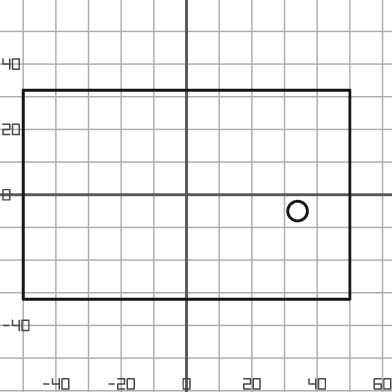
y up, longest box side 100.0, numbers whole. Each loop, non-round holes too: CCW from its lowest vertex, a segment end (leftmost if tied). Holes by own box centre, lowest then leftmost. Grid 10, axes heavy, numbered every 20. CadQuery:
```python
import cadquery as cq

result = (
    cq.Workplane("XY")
    .moveTo(-50.0, -32.0)
    .lineTo(50.0, -32.0)
    .lineTo(50.0, 32.0)
    .lineTo(-50.0, 32.0)
    .close()
    .moveTo(34.0, -5.0)
    .circle(3.0)
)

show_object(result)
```